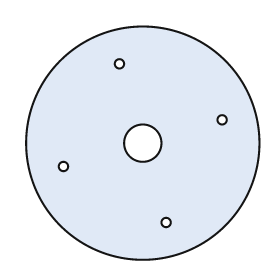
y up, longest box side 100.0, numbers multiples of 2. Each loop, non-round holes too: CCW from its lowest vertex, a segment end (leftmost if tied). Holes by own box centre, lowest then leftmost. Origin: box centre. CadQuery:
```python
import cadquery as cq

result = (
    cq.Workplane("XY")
    .moveTo(0.0, 0.0)
    .circle(50.0)
    .moveTo(10.0, -34.0)
    .circle(2.0)
    .moveTo(-34.0, -10.0)
    .circle(2.0)
    .moveTo(0.0, 0.0)
    .circle(8.0)
    .moveTo(34.0, 10.0)
    .circle(2.0)
    .moveTo(-10.0, 34.0)
    .circle(2.0)
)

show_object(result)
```